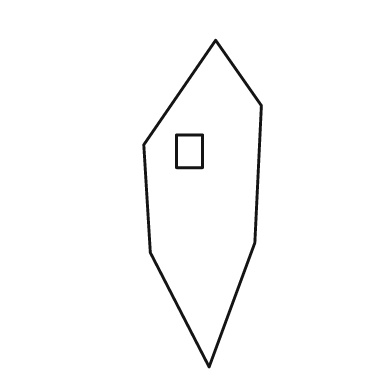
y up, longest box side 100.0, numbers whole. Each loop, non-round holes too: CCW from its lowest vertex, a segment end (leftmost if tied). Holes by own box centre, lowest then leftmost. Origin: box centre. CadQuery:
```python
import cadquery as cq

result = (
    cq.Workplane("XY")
    .moveTo(2.0, -50.0)
    .lineTo(16.0, -12.0)
    .lineTo(18.0, 30.0)
    .lineTo(4.0, 50.0)
    .lineTo(-18.0, 18.0)
    .lineTo(-16.0, -15.0)
    .close()
    .moveTo(-8.0, 11.0)
    .lineTo(0.0, 11.0)
    .lineTo(0.0, 21.0)
    .lineTo(-8.0, 21.0)
    .close()
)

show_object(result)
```